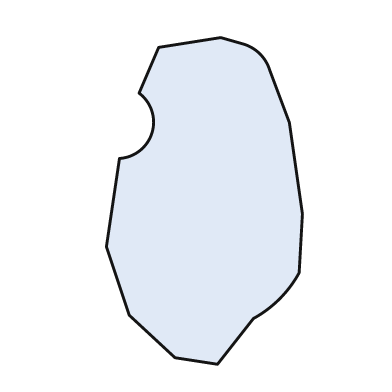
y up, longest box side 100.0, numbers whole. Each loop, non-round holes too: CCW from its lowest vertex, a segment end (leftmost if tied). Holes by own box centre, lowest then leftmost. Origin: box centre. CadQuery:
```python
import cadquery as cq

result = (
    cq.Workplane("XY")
    .moveTo(4.0, -50.0)
    .lineTo(15.0, -36.0)
    .threePointArc((23.0, -30.0), (29.0, -22.0))
    .lineTo(30.0, -4.0)
    .lineTo(26.0, 24.0)
    .lineTo(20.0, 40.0)
    .threePointArc((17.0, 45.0), (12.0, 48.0))
    .lineTo(5.0, 50.0)
    .lineTo(-14.0, 47.0)
    .lineTo(-20.0, 33.0)
    .threePointArc((-16.0, 21.0), (-26.0, 13.0))
    .lineTo(-30.0, -14.0)
    .lineTo(-23.0, -35.0)
    .lineTo(-9.0, -48.0)
    .close()
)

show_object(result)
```